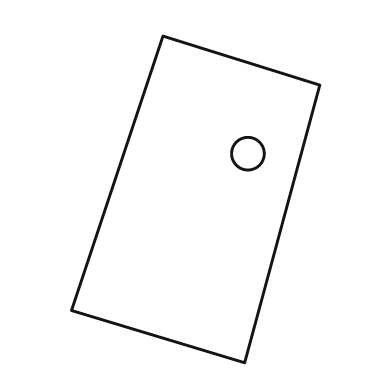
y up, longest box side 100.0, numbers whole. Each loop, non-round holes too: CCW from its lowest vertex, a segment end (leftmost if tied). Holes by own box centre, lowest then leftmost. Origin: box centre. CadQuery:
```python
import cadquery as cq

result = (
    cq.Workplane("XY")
    .moveTo(15.0, -50.0)
    .lineTo(38.0, 35.0)
    .lineTo(-10.0, 50.0)
    .lineTo(-38.0, -34.0)
    .close()
    .moveTo(16.0, 14.0)
    .circle(5.0)
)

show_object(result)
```